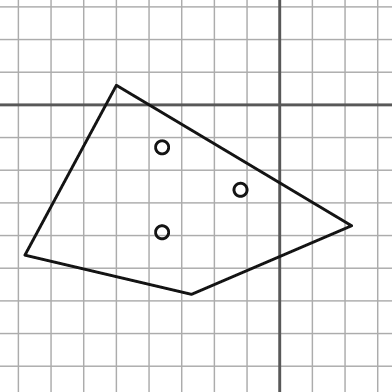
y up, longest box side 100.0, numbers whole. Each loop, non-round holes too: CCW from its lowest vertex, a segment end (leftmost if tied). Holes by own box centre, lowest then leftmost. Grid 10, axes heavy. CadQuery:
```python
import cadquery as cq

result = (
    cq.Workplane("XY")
    .moveTo(-27.0, -58.0)
    .lineTo(22.0, -37.0)
    .lineTo(-50.0, 6.0)
    .lineTo(-78.0, -46.0)
    .close()
    .moveTo(-36.0, -39.0)
    .circle(2.0)
    .moveTo(-12.0, -26.0)
    .circle(2.0)
    .moveTo(-36.0, -13.0)
    .circle(2.0)
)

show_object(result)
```